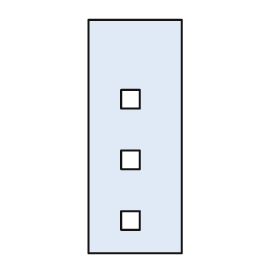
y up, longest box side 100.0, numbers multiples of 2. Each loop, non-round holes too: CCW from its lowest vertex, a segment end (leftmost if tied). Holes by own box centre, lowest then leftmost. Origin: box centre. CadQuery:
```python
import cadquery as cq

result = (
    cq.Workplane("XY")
    .moveTo(-20.0, -50.0)
    .lineTo(20.0, -50.0)
    .lineTo(20.0, 50.0)
    .lineTo(-20.0, 50.0)
    .close()
    .moveTo(-6.0, -40.0)
    .lineTo(2.0, -40.0)
    .lineTo(2.0, -32.0)
    .lineTo(-6.0, -32.0)
    .close()
    .moveTo(-6.0, -14.0)
    .lineTo(2.0, -14.0)
    .lineTo(2.0, -6.0)
    .lineTo(-6.0, -6.0)
    .close()
    .moveTo(-6.0, 12.0)
    .lineTo(2.0, 12.0)
    .lineTo(2.0, 20.0)
    .lineTo(-6.0, 20.0)
    .close()
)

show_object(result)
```